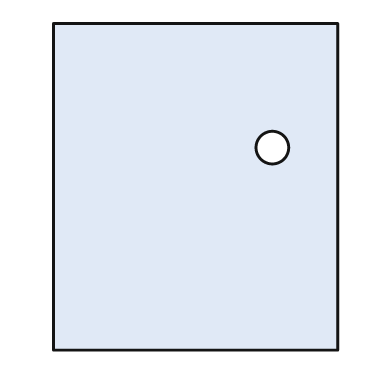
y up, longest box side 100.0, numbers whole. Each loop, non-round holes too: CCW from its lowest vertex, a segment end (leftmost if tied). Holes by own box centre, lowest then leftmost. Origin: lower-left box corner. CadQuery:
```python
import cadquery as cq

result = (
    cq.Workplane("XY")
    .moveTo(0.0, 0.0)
    .lineTo(87.0, 0.0)
    .lineTo(87.0, 100.0)
    .lineTo(0.0, 100.0)
    .close()
    .moveTo(67.0, 62.0)
    .circle(5.0)
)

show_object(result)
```